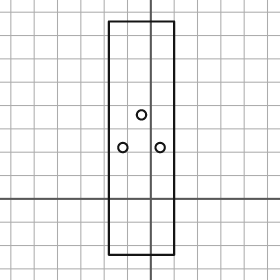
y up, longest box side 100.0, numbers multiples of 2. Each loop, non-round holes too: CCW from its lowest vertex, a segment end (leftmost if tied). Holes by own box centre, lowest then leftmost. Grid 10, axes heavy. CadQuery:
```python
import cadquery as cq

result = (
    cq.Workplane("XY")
    .moveTo(-18.0, -24.0)
    .lineTo(10.0, -24.0)
    .lineTo(10.0, 76.0)
    .lineTo(-18.0, 76.0)
    .close()
    .moveTo(-12.0, 22.0)
    .circle(2.0)
    .moveTo(4.0, 22.0)
    .circle(2.0)
    .moveTo(-4.0, 36.0)
    .circle(2.0)
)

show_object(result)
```